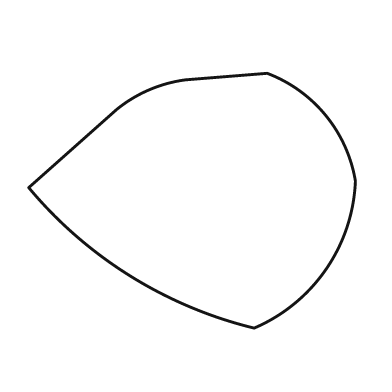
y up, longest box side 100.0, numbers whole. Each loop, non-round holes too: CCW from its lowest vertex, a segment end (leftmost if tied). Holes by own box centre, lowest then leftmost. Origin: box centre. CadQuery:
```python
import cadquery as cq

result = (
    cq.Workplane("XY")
    .moveTo(19.0, -39.0)
    .threePointArc((41.0, -21.0), (50.0, 6.0))
    .threePointArc((41.0, 26.0), (23.0, 39.0))
    .lineTo(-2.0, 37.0)
    .threePointArc((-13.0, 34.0), (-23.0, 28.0))
    .lineTo(-50.0, 4.0)
    .threePointArc((-19.0, -23.0), (19.0, -39.0))
    .close()
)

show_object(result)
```